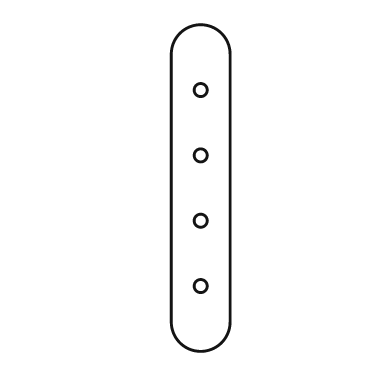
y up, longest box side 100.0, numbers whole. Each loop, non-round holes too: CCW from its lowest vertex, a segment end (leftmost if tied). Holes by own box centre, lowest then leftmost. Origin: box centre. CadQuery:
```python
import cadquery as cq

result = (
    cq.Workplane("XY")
    .moveTo(-9.0, -41.0)
    .threePointArc((0.0, -50.0), (9.0, -41.0))
    .lineTo(9.0, 41.0)
    .threePointArc((0.0, 50.0), (-9.0, 41.0))
    .close()
    .moveTo(0.0, -30.0)
    .circle(2.0)
    .moveTo(0.0, -10.0)
    .circle(2.0)
    .moveTo(0.0, 10.0)
    .circle(2.0)
    .moveTo(0.0, 30.0)
    .circle(2.0)
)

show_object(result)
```